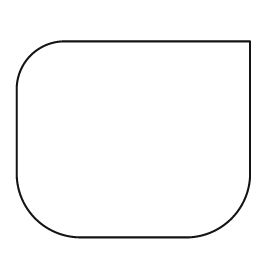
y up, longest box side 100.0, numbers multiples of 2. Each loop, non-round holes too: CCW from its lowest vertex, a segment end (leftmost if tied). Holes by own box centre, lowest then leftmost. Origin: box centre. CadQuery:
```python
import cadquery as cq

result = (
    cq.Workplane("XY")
    .moveTo(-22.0, -42.0)
    .lineTo(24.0, -42.0)
    .threePointArc((42.0, -34.0), (50.0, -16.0))
    .lineTo(50.0, 42.0)
    .lineTo(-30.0, 42.0)
    .threePointArc((-44.0, 36.0), (-50.0, 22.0))
    .lineTo(-50.0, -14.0)
    .threePointArc((-42.0, -34.0), (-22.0, -42.0))
    .close()
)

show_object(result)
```